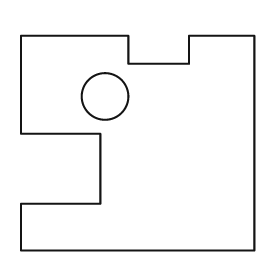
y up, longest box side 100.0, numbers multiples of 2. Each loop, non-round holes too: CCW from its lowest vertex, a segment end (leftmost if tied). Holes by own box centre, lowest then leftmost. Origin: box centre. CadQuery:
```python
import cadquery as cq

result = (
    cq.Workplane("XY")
    .moveTo(-50.0, -46.0)
    .lineTo(50.0, -46.0)
    .lineTo(50.0, 46.0)
    .lineTo(22.0, 46.0)
    .lineTo(22.0, 34.0)
    .lineTo(-4.0, 34.0)
    .lineTo(-4.0, 46.0)
    .lineTo(-50.0, 46.0)
    .lineTo(-50.0, 4.0)
    .lineTo(-16.0, 4.0)
    .lineTo(-16.0, -26.0)
    .lineTo(-50.0, -26.0)
    .close()
    .moveTo(-14.0, 20.0)
    .circle(10.0)
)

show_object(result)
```